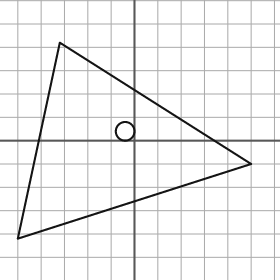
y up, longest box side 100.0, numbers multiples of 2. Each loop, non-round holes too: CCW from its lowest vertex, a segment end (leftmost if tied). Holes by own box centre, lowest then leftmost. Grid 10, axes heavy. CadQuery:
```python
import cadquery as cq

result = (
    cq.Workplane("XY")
    .moveTo(-50.0, -42.0)
    .lineTo(50.0, -10.0)
    .lineTo(-32.0, 42.0)
    .close()
    .moveTo(-4.0, 4.0)
    .circle(4.0)
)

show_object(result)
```